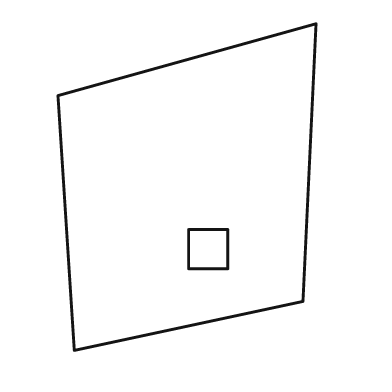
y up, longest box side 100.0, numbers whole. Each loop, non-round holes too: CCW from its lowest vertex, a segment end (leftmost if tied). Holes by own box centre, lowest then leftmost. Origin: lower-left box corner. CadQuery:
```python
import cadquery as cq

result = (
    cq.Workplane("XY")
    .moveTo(5.0, 0.0)
    .lineTo(75.0, 15.0)
    .lineTo(79.0, 100.0)
    .lineTo(0.0, 78.0)
    .close()
    .moveTo(40.0, 25.0)
    .lineTo(52.0, 25.0)
    .lineTo(52.0, 37.0)
    .lineTo(40.0, 37.0)
    .close()
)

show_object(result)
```